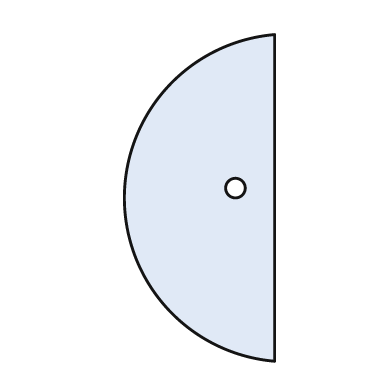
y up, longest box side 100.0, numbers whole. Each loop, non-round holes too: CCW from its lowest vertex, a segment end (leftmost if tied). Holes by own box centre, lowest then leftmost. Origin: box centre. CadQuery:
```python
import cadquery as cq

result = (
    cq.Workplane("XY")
    .moveTo(23.0, -50.0)
    .lineTo(23.0, 50.0)
    .threePointArc((-23.0, 0.0), (23.0, -50.0))
    .close()
    .moveTo(11.0, 3.0)
    .circle(3.0)
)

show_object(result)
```